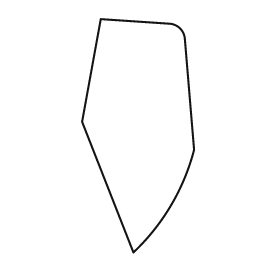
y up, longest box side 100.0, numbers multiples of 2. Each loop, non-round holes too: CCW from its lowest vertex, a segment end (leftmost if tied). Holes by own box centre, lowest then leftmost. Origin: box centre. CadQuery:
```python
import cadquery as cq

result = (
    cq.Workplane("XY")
    .moveTo(-2.0, -50.0)
    .threePointArc((14.0, -30.0), (24.0, -6.0))
    .lineTo(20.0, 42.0)
    .threePointArc((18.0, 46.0), (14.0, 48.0))
    .lineTo(-16.0, 50.0)
    .lineTo(-24.0, 6.0)
    .close()
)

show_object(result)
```